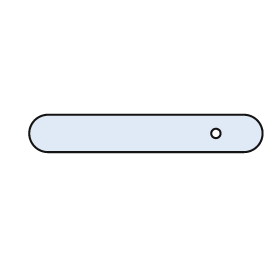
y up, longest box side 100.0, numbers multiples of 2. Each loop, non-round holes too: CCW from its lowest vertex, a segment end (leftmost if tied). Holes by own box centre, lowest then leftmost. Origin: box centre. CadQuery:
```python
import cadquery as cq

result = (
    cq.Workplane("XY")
    .moveTo(-42.0, -8.0)
    .lineTo(42.0, -8.0)
    .threePointArc((50.0, 0.0), (42.0, 8.0))
    .lineTo(-42.0, 8.0)
    .threePointArc((-50.0, 0.0), (-42.0, -8.0))
    .close()
    .moveTo(30.0, 0.0)
    .circle(2.0)
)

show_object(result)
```